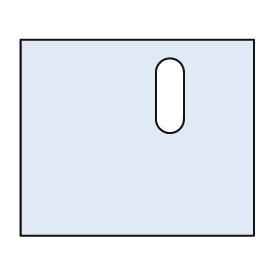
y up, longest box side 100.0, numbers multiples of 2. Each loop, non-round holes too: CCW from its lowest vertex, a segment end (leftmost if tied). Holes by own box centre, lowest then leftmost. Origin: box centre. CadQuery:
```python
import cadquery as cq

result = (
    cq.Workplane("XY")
    .moveTo(-50.0, -42.0)
    .lineTo(50.0, -42.0)
    .lineTo(50.0, 42.0)
    .lineTo(-50.0, 42.0)
    .close()
    .moveTo(8.0, 8.0)
    .threePointArc((14.0, 2.0), (20.0, 8.0))
    .lineTo(20.0, 28.0)
    .threePointArc((14.0, 34.0), (8.0, 28.0))
    .close()
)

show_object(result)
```